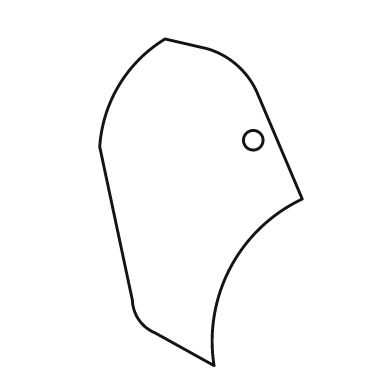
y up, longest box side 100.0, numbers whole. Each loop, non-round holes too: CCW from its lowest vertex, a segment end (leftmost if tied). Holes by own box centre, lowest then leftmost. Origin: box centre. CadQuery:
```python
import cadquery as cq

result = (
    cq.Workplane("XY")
    .moveTo(4.0, -50.0)
    .threePointArc((9.0, -20.0), (31.0, 1.0))
    .lineTo(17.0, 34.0)
    .threePointArc((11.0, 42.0), (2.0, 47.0))
    .lineTo(-11.0, 50.0)
    .threePointArc((-25.0, 36.0), (-31.0, 17.0))
    .lineTo(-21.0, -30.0)
    .threePointArc((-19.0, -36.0), (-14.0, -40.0))
    .close()
    .moveTo(16.0, 19.0)
    .circle(3.0)
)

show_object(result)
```